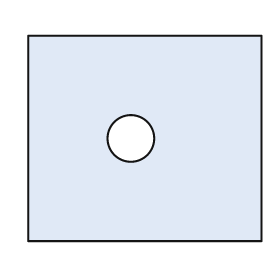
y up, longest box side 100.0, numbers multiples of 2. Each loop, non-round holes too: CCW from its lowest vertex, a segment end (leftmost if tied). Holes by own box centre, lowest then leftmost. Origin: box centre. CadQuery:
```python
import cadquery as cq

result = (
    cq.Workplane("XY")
    .moveTo(-50.0, -44.0)
    .lineTo(50.0, -44.0)
    .lineTo(50.0, 44.0)
    .lineTo(-50.0, 44.0)
    .close()
    .moveTo(-6.0, 0.0)
    .circle(10.0)
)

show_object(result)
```